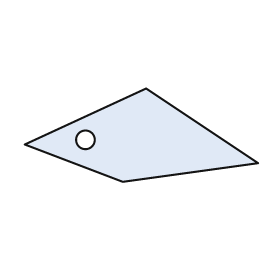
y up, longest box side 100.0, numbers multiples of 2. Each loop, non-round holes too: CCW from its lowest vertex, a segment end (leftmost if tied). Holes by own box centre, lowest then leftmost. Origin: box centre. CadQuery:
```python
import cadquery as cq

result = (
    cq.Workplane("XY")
    .moveTo(-8.0, -20.0)
    .lineTo(50.0, -12.0)
    .lineTo(2.0, 20.0)
    .lineTo(-50.0, -4.0)
    .close()
    .moveTo(-24.0, -2.0)
    .circle(4.0)
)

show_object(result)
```